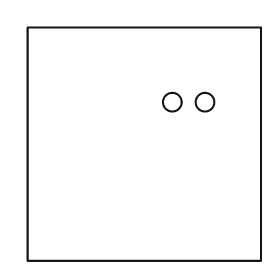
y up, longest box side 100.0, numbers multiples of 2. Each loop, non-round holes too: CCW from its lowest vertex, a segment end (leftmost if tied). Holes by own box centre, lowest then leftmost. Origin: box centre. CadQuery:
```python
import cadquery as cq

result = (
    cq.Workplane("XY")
    .moveTo(-50.0, -50.0)
    .lineTo(50.0, -50.0)
    .lineTo(50.0, 50.0)
    .lineTo(-50.0, 50.0)
    .close()
    .moveTo(12.0, 18.0)
    .circle(4.0)
    .moveTo(26.0, 18.0)
    .circle(4.0)
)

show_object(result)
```